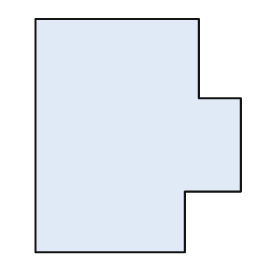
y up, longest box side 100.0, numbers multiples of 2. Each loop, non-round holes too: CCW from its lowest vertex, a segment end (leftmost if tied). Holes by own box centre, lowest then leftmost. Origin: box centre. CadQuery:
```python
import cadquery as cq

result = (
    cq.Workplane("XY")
    .moveTo(-44.0, -50.0)
    .lineTo(20.0, -50.0)
    .lineTo(20.0, -24.0)
    .lineTo(44.0, -24.0)
    .lineTo(44.0, 16.0)
    .lineTo(26.0, 16.0)
    .lineTo(26.0, 50.0)
    .lineTo(-44.0, 50.0)
    .close()
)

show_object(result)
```